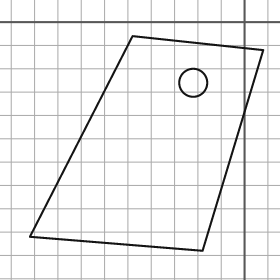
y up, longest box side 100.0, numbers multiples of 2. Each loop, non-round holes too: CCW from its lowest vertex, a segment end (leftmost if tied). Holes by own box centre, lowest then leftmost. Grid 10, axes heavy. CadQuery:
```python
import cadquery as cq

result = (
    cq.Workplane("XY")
    .moveTo(-18.0, -98.0)
    .lineTo(8.0, -12.0)
    .lineTo(-48.0, -6.0)
    .lineTo(-92.0, -92.0)
    .close()
    .moveTo(-22.0, -26.0)
    .circle(6.0)
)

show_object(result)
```